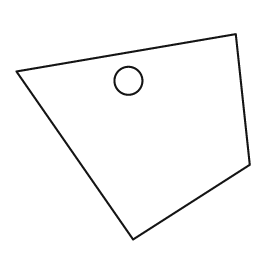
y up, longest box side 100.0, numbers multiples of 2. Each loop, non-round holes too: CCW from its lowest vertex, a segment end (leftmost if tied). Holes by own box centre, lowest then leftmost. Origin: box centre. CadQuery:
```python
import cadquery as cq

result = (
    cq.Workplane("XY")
    .moveTo(0.0, -44.0)
    .lineTo(50.0, -12.0)
    .lineTo(44.0, 44.0)
    .lineTo(-50.0, 28.0)
    .close()
    .moveTo(-2.0, 24.0)
    .circle(6.0)
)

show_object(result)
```